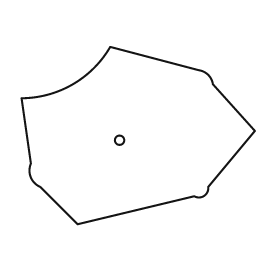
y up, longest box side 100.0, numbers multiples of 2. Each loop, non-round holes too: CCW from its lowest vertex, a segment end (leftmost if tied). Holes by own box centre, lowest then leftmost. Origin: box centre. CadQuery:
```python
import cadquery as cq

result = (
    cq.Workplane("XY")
    .moveTo(-26.0, -38.0)
    .lineTo(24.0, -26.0)
    .threePointArc((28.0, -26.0), (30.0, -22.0))
    .lineTo(50.0, 2.0)
    .lineTo(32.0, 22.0)
    .threePointArc((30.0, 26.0), (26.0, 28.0))
    .lineTo(-12.0, 38.0)
    .threePointArc((-28.0, 22.0), (-50.0, 16.0))
    .lineTo(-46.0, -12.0)
    .threePointArc((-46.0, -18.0), (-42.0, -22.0))
    .close()
    .moveTo(-8.0, -2.0)
    .circle(2.0)
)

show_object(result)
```